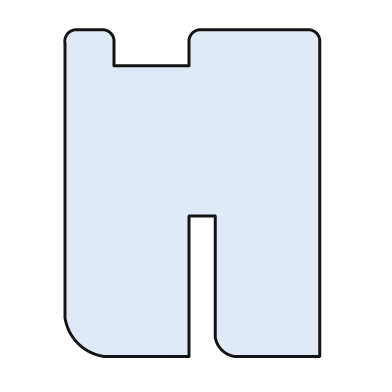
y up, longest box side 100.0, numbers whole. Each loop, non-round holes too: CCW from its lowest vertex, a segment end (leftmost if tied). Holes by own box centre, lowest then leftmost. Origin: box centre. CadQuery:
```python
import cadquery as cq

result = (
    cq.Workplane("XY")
    .moveTo(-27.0, -50.0)
    .lineTo(-1.0, -50.0)
    .lineTo(-1.0, -7.0)
    .lineTo(7.0, -7.0)
    .lineTo(7.0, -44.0)
    .threePointArc((9.0, -48.0), (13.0, -50.0))
    .lineTo(39.0, -50.0)
    .lineTo(39.0, 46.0)
    .threePointArc((38.0, 49.0), (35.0, 50.0))
    .lineTo(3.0, 50.0)
    .threePointArc((0.0, 49.0), (-1.0, 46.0))
    .lineTo(-1.0, 39.0)
    .lineTo(-24.0, 39.0)
    .lineTo(-24.0, 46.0)
    .threePointArc((-25.0, 49.0), (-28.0, 50.0))
    .lineTo(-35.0, 50.0)
    .threePointArc((-38.0, 49.0), (-39.0, 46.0))
    .lineTo(-39.0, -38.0)
    .threePointArc((-35.0, -46.0), (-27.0, -50.0))
    .close()
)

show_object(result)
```